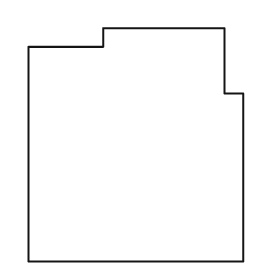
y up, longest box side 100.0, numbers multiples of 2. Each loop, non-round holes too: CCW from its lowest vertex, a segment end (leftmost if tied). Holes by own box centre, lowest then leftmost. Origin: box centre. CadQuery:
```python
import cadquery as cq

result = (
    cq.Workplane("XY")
    .moveTo(-46.0, -50.0)
    .lineTo(46.0, -50.0)
    .lineTo(46.0, 22.0)
    .lineTo(38.0, 22.0)
    .lineTo(38.0, 50.0)
    .lineTo(-14.0, 50.0)
    .lineTo(-14.0, 42.0)
    .lineTo(-46.0, 42.0)
    .close()
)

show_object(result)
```